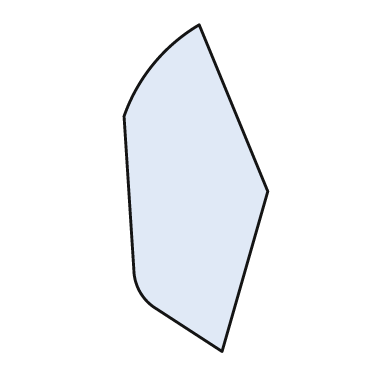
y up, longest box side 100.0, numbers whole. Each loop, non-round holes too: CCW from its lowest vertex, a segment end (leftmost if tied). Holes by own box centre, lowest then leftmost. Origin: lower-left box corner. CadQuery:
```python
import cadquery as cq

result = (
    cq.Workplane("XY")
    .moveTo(30.0, 0.0)
    .lineTo(44.0, 49.0)
    .lineTo(23.0, 100.0)
    .threePointArc((9.0, 88.0), (0.0, 72.0))
    .lineTo(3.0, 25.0)
    .threePointArc((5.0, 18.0), (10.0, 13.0))
    .close()
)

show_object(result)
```